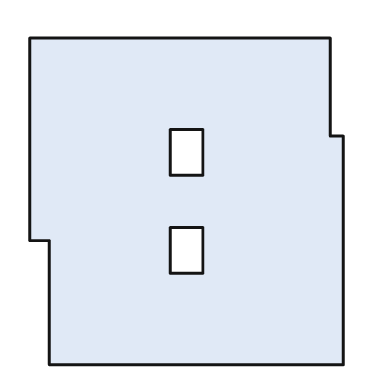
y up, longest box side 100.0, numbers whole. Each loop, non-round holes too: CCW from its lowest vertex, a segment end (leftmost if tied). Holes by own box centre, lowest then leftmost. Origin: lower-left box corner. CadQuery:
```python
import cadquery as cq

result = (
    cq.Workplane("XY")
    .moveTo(6.0, 0.0)
    .lineTo(96.0, 0.0)
    .lineTo(96.0, 70.0)
    .lineTo(92.0, 70.0)
    .lineTo(92.0, 100.0)
    .lineTo(0.0, 100.0)
    .lineTo(0.0, 38.0)
    .lineTo(6.0, 38.0)
    .close()
    .moveTo(43.0, 28.0)
    .lineTo(53.0, 28.0)
    .lineTo(53.0, 42.0)
    .lineTo(43.0, 42.0)
    .close()
    .moveTo(43.0, 58.0)
    .lineTo(53.0, 58.0)
    .lineTo(53.0, 72.0)
    .lineTo(43.0, 72.0)
    .close()
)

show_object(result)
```